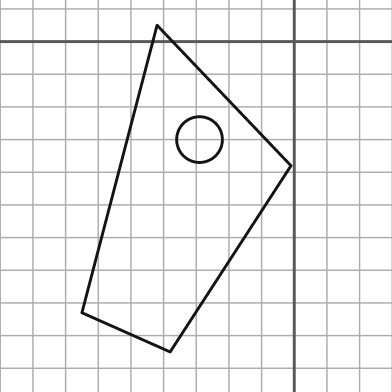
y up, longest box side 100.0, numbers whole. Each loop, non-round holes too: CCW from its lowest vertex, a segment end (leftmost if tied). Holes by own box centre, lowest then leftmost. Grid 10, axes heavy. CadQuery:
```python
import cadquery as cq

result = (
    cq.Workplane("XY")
    .moveTo(-38.0, -95.0)
    .lineTo(-1.0, -38.0)
    .lineTo(-42.0, 5.0)
    .lineTo(-65.0, -83.0)
    .close()
    .moveTo(-29.0, -30.0)
    .circle(7.0)
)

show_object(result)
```